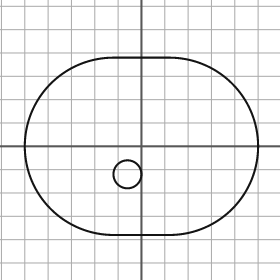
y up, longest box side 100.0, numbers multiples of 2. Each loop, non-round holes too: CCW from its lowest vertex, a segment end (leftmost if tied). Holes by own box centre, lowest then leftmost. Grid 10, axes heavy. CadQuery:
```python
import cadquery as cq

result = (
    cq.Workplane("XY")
    .moveTo(-12.0, -38.0)
    .lineTo(12.0, -38.0)
    .threePointArc((50.0, 0.0), (12.0, 38.0))
    .lineTo(-12.0, 38.0)
    .threePointArc((-50.0, 0.0), (-12.0, -38.0))
    .close()
    .moveTo(-6.0, -12.0)
    .circle(6.0)
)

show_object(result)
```